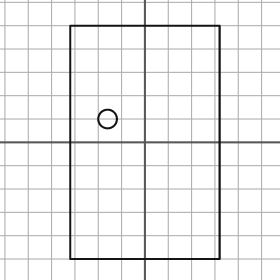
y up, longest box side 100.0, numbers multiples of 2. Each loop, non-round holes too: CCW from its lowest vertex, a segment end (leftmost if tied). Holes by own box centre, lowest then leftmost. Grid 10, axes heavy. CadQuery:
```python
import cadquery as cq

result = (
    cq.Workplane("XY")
    .moveTo(-32.0, -50.0)
    .lineTo(32.0, -50.0)
    .lineTo(32.0, 50.0)
    .lineTo(-32.0, 50.0)
    .close()
    .moveTo(-16.0, 10.0)
    .circle(4.0)
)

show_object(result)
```